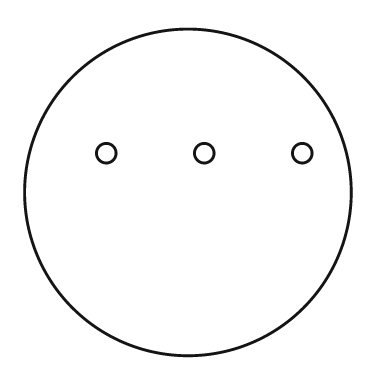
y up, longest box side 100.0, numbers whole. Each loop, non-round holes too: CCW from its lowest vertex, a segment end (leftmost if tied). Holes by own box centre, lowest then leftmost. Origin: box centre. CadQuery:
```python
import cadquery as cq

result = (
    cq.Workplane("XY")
    .moveTo(0.0, 0.0)
    .circle(50.0)
    .moveTo(-25.0, 12.0)
    .circle(3.0)
    .moveTo(5.0, 12.0)
    .circle(3.0)
    .moveTo(35.0, 12.0)
    .circle(3.0)
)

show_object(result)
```